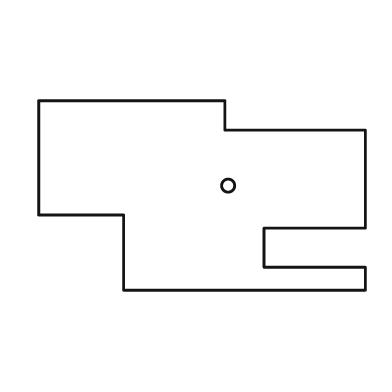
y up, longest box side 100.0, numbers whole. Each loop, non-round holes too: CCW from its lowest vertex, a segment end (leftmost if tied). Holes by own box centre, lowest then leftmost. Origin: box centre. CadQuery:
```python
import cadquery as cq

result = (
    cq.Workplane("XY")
    .moveTo(-24.0, -29.0)
    .lineTo(50.0, -29.0)
    .lineTo(50.0, -22.0)
    .lineTo(19.0, -22.0)
    .lineTo(19.0, -10.0)
    .lineTo(50.0, -10.0)
    .lineTo(50.0, 20.0)
    .lineTo(7.0, 20.0)
    .lineTo(7.0, 29.0)
    .lineTo(-50.0, 29.0)
    .lineTo(-50.0, -6.0)
    .lineTo(-24.0, -6.0)
    .close()
    .moveTo(8.0, 3.0)
    .circle(2.0)
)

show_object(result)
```